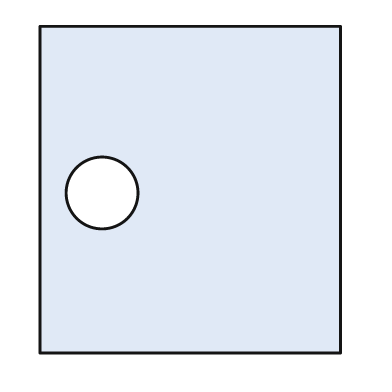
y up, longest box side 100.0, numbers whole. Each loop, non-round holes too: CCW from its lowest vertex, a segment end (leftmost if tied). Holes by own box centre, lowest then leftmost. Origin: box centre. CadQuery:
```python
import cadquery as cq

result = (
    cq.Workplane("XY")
    .moveTo(-46.0, -50.0)
    .lineTo(46.0, -50.0)
    .lineTo(46.0, 50.0)
    .lineTo(-46.0, 50.0)
    .close()
    .moveTo(-27.0, -1.0)
    .circle(11.0)
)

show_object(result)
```